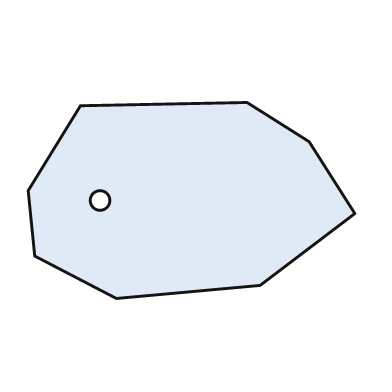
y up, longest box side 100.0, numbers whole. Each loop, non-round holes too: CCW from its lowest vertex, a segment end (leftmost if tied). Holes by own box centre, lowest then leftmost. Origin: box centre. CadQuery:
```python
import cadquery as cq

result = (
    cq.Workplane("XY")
    .moveTo(-23.0, -30.0)
    .lineTo(21.0, -26.0)
    .lineTo(50.0, -4.0)
    .lineTo(36.0, 18.0)
    .lineTo(17.0, 30.0)
    .lineTo(-34.0, 29.0)
    .lineTo(-50.0, 3.0)
    .lineTo(-48.0, -17.0)
    .close()
    .moveTo(-28.0, 0.0)
    .circle(3.0)
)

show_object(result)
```